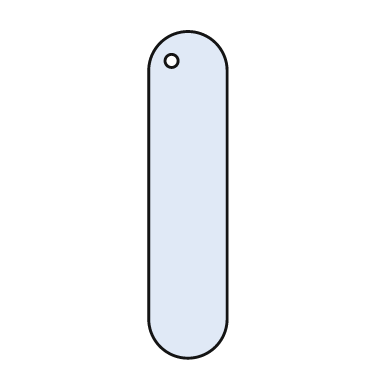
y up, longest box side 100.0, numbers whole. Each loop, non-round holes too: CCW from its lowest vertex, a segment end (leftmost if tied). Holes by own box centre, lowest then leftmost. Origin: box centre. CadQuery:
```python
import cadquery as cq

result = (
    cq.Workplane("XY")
    .moveTo(-12.0, -38.0)
    .threePointArc((0.0, -50.0), (12.0, -38.0))
    .lineTo(12.0, 38.0)
    .threePointArc((0.0, 50.0), (-12.0, 38.0))
    .close()
    .moveTo(-5.0, 41.0)
    .circle(2.0)
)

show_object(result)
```